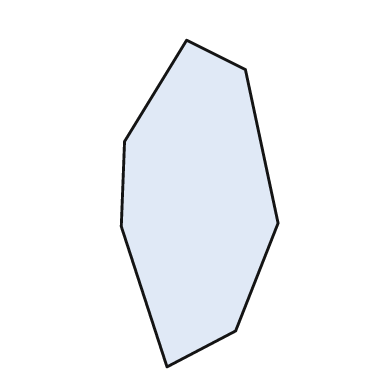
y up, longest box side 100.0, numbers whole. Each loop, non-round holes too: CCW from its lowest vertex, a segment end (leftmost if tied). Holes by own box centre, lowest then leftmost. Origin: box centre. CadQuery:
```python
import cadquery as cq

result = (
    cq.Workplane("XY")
    .moveTo(-10.0, -50.0)
    .lineTo(11.0, -39.0)
    .lineTo(24.0, -6.0)
    .lineTo(14.0, 41.0)
    .lineTo(-4.0, 50.0)
    .lineTo(-23.0, 19.0)
    .lineTo(-24.0, -7.0)
    .close()
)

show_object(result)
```